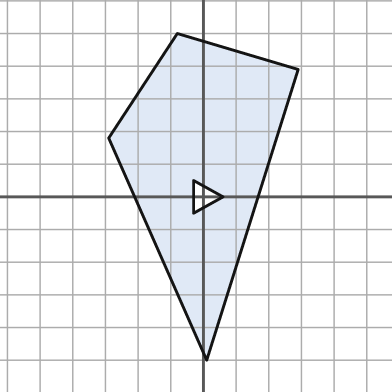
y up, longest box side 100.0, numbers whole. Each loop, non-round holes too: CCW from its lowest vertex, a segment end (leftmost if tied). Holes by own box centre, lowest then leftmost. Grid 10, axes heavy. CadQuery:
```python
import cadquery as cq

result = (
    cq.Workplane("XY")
    .moveTo(1.0, -50.0)
    .lineTo(29.0, 39.0)
    .lineTo(-8.0, 50.0)
    .lineTo(-29.0, 18.0)
    .close()
    .moveTo(-3.0, -5.0)
    .lineTo(6.0, 0.0)
    .lineTo(-3.0, 5.0)
    .close()
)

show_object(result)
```